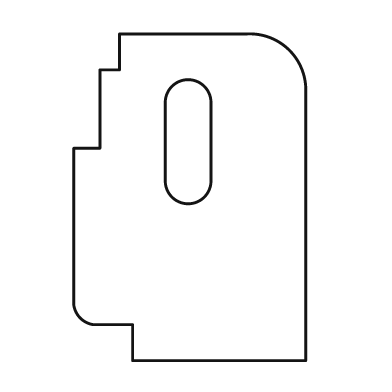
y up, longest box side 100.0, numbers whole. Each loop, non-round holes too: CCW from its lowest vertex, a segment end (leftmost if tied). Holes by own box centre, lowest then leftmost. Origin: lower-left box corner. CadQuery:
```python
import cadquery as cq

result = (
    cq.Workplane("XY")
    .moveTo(18.0, 0.0)
    .lineTo(71.0, 0.0)
    .lineTo(71.0, 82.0)
    .threePointArc((66.0, 95.0), (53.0, 100.0))
    .lineTo(14.0, 100.0)
    .lineTo(14.0, 89.0)
    .lineTo(8.0, 89.0)
    .lineTo(8.0, 65.0)
    .lineTo(0.0, 65.0)
    .lineTo(0.0, 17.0)
    .threePointArc((2.0, 13.0), (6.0, 11.0))
    .lineTo(18.0, 11.0)
    .close()
    .moveTo(28.0, 55.0)
    .threePointArc((35.0, 48.0), (42.0, 55.0))
    .lineTo(42.0, 79.0)
    .threePointArc((35.0, 86.0), (28.0, 79.0))
    .close()
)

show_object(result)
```